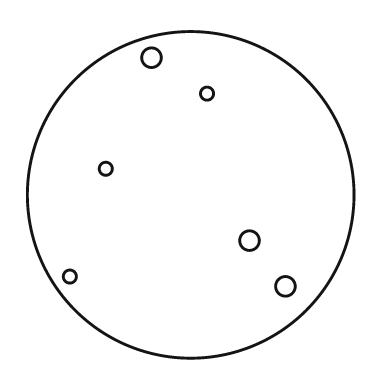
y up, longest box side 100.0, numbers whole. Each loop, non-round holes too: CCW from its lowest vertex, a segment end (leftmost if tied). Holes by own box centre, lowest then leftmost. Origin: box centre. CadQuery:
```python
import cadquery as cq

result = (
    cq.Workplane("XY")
    .moveTo(0.0, 0.0)
    .circle(50.0)
    .moveTo(29.0, -28.0)
    .circle(3.0)
    .moveTo(-37.0, -25.0)
    .circle(2.0)
    .moveTo(18.0, -14.0)
    .circle(3.0)
    .moveTo(-26.0, 8.0)
    .circle(2.0)
    .moveTo(5.0, 31.0)
    .circle(2.0)
    .moveTo(-12.0, 42.0)
    .circle(3.0)
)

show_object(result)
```